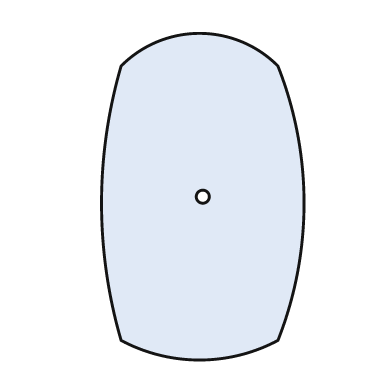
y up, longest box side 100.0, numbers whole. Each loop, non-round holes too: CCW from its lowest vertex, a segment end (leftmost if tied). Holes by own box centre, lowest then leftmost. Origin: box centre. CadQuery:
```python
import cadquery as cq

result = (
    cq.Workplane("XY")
    .moveTo(-25.0, -44.0)
    .threePointArc((-1.0, -50.0), (23.0, -44.0))
    .threePointArc((31.0, -2.0), (23.0, 40.0))
    .threePointArc((-1.0, 50.0), (-25.0, 40.0))
    .threePointArc((-31.0, -2.0), (-25.0, -44.0))
    .close()
    .moveTo(0.0, 0.0)
    .circle(2.0)
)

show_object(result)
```